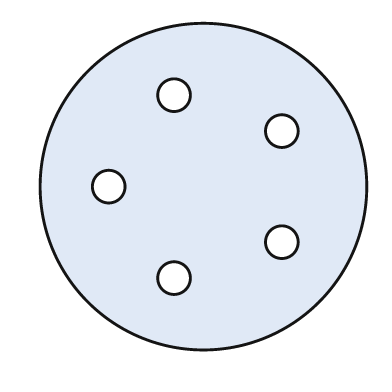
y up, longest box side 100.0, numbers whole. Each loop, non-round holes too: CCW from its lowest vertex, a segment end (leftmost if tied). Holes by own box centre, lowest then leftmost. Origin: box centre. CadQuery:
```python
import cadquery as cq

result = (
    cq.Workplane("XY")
    .moveTo(0.0, 0.0)
    .circle(50.0)
    .moveTo(-9.0, -28.0)
    .circle(5.0)
    .moveTo(24.0, -17.0)
    .circle(5.0)
    .moveTo(-29.0, 0.0)
    .circle(5.0)
    .moveTo(24.0, 17.0)
    .circle(5.0)
    .moveTo(-9.0, 28.0)
    .circle(5.0)
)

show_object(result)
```